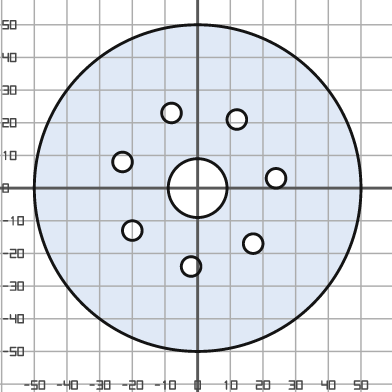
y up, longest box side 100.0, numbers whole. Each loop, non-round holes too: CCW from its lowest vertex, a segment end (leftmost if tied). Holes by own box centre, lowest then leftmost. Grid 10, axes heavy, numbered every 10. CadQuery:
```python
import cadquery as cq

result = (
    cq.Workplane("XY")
    .moveTo(0.0, 0.0)
    .circle(50.0)
    .moveTo(-2.0, -24.0)
    .circle(3.0)
    .moveTo(17.0, -17.0)
    .circle(3.0)
    .moveTo(-20.0, -13.0)
    .circle(3.0)
    .moveTo(0.0, 0.0)
    .circle(9.0)
    .moveTo(24.0, 3.0)
    .circle(3.0)
    .moveTo(-23.0, 8.0)
    .circle(3.0)
    .moveTo(12.0, 21.0)
    .circle(3.0)
    .moveTo(-8.0, 23.0)
    .circle(3.0)
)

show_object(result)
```